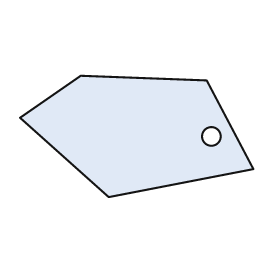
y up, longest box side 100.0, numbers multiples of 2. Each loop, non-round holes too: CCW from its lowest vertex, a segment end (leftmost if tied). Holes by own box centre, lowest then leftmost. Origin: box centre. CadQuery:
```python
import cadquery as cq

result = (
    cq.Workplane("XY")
    .moveTo(-12.0, -26.0)
    .lineTo(50.0, -14.0)
    .lineTo(30.0, 24.0)
    .lineTo(-24.0, 26.0)
    .lineTo(-50.0, 8.0)
    .close()
    .moveTo(32.0, 0.0)
    .circle(4.0)
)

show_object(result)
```